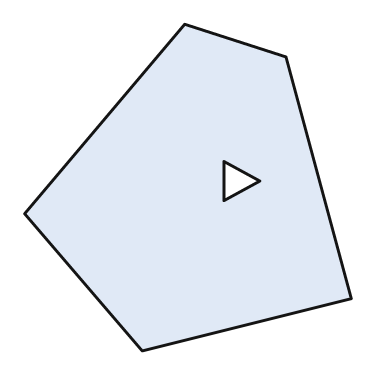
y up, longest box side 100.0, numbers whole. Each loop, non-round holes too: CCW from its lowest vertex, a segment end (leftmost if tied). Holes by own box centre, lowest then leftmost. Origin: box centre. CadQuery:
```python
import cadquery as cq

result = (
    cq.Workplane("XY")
    .moveTo(-14.0, -50.0)
    .lineTo(50.0, -34.0)
    .lineTo(30.0, 40.0)
    .lineTo(-1.0, 50.0)
    .lineTo(-50.0, -8.0)
    .close()
    .moveTo(11.0, -4.0)
    .lineTo(22.0, 2.0)
    .lineTo(11.0, 8.0)
    .close()
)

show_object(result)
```